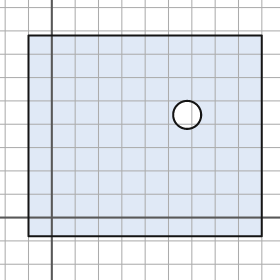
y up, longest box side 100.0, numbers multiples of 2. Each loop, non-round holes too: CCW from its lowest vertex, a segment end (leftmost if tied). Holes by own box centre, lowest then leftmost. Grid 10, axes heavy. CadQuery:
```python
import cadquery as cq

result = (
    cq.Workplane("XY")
    .moveTo(-10.0, -8.0)
    .lineTo(90.0, -8.0)
    .lineTo(90.0, 78.0)
    .lineTo(-10.0, 78.0)
    .close()
    .moveTo(58.0, 44.0)
    .circle(6.0)
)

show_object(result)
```